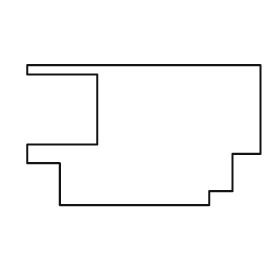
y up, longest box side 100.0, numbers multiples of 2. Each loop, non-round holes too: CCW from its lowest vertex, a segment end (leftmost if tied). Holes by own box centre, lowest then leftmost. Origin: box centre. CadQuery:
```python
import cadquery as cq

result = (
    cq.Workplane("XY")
    .moveTo(-36.0, -30.0)
    .lineTo(28.0, -30.0)
    .lineTo(28.0, -24.0)
    .lineTo(38.0, -24.0)
    .lineTo(38.0, -8.0)
    .lineTo(50.0, -8.0)
    .lineTo(50.0, 30.0)
    .lineTo(-50.0, 30.0)
    .lineTo(-50.0, 26.0)
    .lineTo(-20.0, 26.0)
    .lineTo(-20.0, -4.0)
    .lineTo(-50.0, -4.0)
    .lineTo(-50.0, -12.0)
    .lineTo(-36.0, -12.0)
    .close()
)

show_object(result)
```